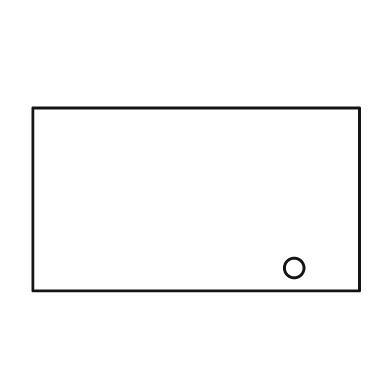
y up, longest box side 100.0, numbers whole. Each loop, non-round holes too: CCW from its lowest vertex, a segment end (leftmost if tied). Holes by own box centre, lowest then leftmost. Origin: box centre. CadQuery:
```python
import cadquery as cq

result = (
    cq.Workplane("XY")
    .moveTo(-50.0, -28.0)
    .lineTo(50.0, -28.0)
    .lineTo(50.0, 28.0)
    .lineTo(-50.0, 28.0)
    .close()
    .moveTo(30.0, -21.0)
    .circle(3.0)
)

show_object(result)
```